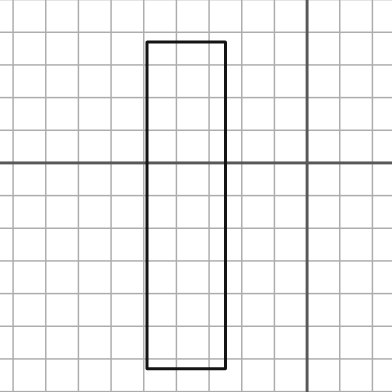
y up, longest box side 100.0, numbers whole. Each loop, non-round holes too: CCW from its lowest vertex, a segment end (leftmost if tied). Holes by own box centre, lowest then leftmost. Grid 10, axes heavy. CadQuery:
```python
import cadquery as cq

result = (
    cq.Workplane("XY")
    .moveTo(-49.0, -63.0)
    .lineTo(-25.0, -63.0)
    .lineTo(-25.0, 37.0)
    .lineTo(-49.0, 37.0)
    .close()
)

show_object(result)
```